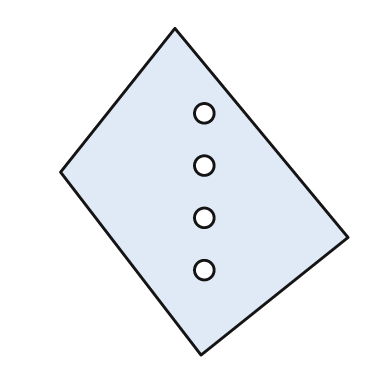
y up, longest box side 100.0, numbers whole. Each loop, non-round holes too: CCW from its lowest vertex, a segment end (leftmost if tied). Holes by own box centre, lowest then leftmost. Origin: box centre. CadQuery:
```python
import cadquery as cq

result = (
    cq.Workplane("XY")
    .moveTo(-1.0, -50.0)
    .lineTo(44.0, -14.0)
    .lineTo(-9.0, 50.0)
    .lineTo(-44.0, 6.0)
    .close()
    .moveTo(0.0, -24.0)
    .circle(3.0)
    .moveTo(0.0, -8.0)
    .circle(3.0)
    .moveTo(0.0, 8.0)
    .circle(3.0)
    .moveTo(0.0, 24.0)
    .circle(3.0)
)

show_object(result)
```